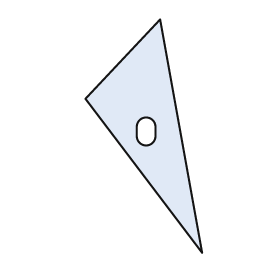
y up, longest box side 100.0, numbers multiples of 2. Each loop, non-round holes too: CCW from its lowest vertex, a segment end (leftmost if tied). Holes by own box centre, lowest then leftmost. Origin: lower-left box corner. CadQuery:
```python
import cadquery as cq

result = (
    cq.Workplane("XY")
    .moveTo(50.0, 0.0)
    .lineTo(32.0, 100.0)
    .lineTo(0.0, 66.0)
    .close()
    .moveTo(22.0, 50.0)
    .threePointArc((26.0, 46.0), (30.0, 50.0))
    .lineTo(30.0, 54.0)
    .threePointArc((26.0, 58.0), (22.0, 54.0))
    .close()
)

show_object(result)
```